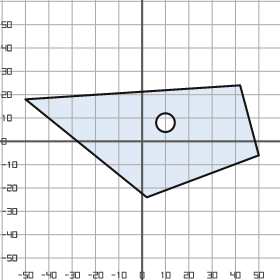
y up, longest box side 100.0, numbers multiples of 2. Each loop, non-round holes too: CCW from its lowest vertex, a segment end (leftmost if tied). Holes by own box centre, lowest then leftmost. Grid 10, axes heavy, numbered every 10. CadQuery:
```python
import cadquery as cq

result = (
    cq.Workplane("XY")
    .moveTo(2.0, -24.0)
    .lineTo(50.0, -6.0)
    .lineTo(42.0, 24.0)
    .lineTo(-50.0, 18.0)
    .close()
    .moveTo(10.0, 8.0)
    .circle(4.0)
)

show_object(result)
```